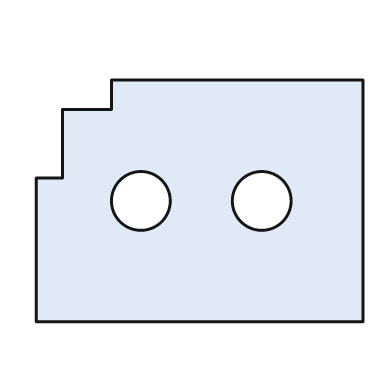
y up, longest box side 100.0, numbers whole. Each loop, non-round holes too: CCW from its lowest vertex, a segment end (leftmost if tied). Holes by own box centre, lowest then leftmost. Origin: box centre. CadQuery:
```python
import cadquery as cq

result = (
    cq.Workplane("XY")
    .moveTo(-50.0, -37.0)
    .lineTo(50.0, -37.0)
    .lineTo(50.0, 37.0)
    .lineTo(-27.0, 37.0)
    .lineTo(-27.0, 28.0)
    .lineTo(-42.0, 28.0)
    .lineTo(-42.0, 7.0)
    .lineTo(-50.0, 7.0)
    .close()
    .moveTo(-18.0, 0.0)
    .circle(9.0)
    .moveTo(19.0, 0.0)
    .circle(9.0)
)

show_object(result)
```